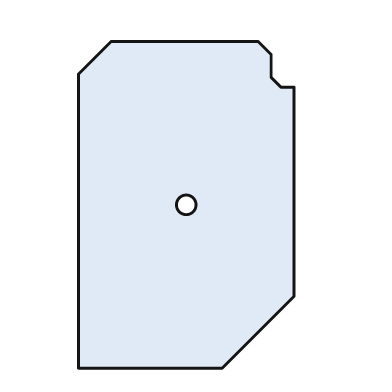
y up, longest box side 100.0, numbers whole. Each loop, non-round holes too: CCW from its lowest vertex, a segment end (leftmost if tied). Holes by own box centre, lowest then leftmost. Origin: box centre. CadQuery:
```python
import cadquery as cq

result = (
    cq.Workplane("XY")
    .moveTo(-33.0, -50.0)
    .lineTo(11.0, -50.0)
    .lineTo(33.0, -28.0)
    .lineTo(33.0, 36.0)
    .lineTo(29.0, 36.0)
    .lineTo(26.0, 39.0)
    .lineTo(26.0, 46.0)
    .lineTo(22.0, 50.0)
    .lineTo(-23.0, 50.0)
    .lineTo(-33.0, 40.0)
    .close()
    .moveTo(0.0, 0.0)
    .circle(3.0)
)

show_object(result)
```